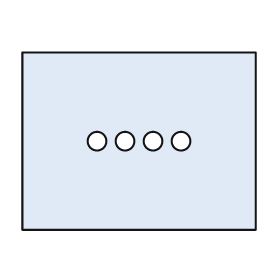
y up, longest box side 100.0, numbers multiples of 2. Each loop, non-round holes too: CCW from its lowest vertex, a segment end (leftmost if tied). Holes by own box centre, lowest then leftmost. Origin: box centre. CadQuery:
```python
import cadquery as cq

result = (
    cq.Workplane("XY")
    .moveTo(-50.0, -38.0)
    .lineTo(50.0, -38.0)
    .lineTo(50.0, 38.0)
    .lineTo(-50.0, 38.0)
    .close()
    .moveTo(-18.0, 0.0)
    .circle(4.0)
    .moveTo(-6.0, 0.0)
    .circle(4.0)
    .moveTo(6.0, 0.0)
    .circle(4.0)
    .moveTo(18.0, 0.0)
    .circle(4.0)
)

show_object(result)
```